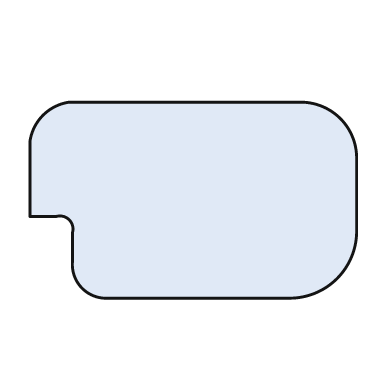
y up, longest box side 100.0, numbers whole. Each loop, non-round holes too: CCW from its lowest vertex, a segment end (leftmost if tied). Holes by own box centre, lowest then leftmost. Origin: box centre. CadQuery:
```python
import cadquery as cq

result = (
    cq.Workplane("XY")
    .moveTo(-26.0, -30.0)
    .lineTo(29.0, -30.0)
    .threePointArc((44.0, -24.0), (50.0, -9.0))
    .lineTo(50.0, 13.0)
    .threePointArc((45.0, 25.0), (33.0, 30.0))
    .lineTo(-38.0, 30.0)
    .threePointArc((-46.0, 26.0), (-50.0, 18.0))
    .lineTo(-50.0, -5.0)
    .lineTo(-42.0, -5.0)
    .threePointArc((-38.0, -6.0), (-37.0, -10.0))
    .lineTo(-37.0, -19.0)
    .threePointArc((-34.0, -27.0), (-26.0, -30.0))
    .close()
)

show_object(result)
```